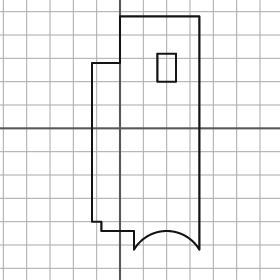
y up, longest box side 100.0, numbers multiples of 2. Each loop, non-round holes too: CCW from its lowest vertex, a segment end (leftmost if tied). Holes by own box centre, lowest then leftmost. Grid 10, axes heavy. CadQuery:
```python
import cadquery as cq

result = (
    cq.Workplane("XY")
    .moveTo(6.0, -52.0)
    .threePointArc((20.0, -44.0), (34.0, -52.0))
    .lineTo(34.0, 48.0)
    .lineTo(0.0, 48.0)
    .lineTo(0.0, 28.0)
    .lineTo(-12.0, 28.0)
    .lineTo(-12.0, -40.0)
    .lineTo(-8.0, -40.0)
    .lineTo(-8.0, -44.0)
    .lineTo(6.0, -44.0)
    .close()
    .moveTo(16.0, 20.0)
    .lineTo(24.0, 20.0)
    .lineTo(24.0, 32.0)
    .lineTo(16.0, 32.0)
    .close()
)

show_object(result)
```